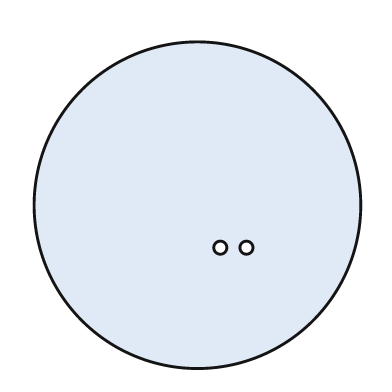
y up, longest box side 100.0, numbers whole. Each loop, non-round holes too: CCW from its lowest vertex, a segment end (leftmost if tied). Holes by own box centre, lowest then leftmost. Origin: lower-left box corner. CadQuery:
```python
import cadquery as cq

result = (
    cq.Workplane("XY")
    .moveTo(50.0, 50.0)
    .circle(50.0)
    .moveTo(57.0, 37.0)
    .circle(2.0)
    .moveTo(65.0, 37.0)
    .circle(2.0)
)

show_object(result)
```